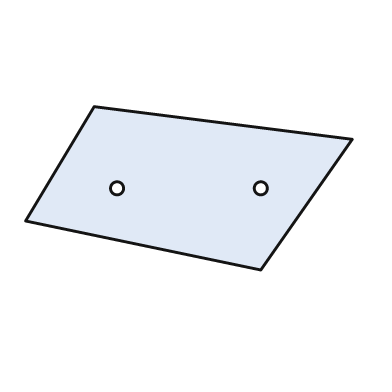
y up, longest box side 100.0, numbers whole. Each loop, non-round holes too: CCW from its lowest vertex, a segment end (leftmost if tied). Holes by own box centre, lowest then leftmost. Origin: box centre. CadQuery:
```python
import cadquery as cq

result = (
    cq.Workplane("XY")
    .moveTo(22.0, -25.0)
    .lineTo(50.0, 15.0)
    .lineTo(-29.0, 25.0)
    .lineTo(-50.0, -10.0)
    .close()
    .moveTo(-22.0, 0.0)
    .circle(2.0)
    .moveTo(22.0, 0.0)
    .circle(2.0)
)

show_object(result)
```